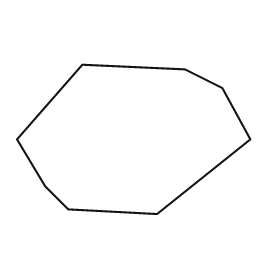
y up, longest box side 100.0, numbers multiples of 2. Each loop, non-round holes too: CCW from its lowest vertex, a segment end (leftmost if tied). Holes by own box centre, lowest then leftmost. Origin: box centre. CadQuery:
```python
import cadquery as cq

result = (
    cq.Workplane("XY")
    .moveTo(10.0, -32.0)
    .lineTo(50.0, 0.0)
    .lineTo(38.0, 22.0)
    .lineTo(22.0, 30.0)
    .lineTo(-22.0, 32.0)
    .lineTo(-50.0, 0.0)
    .lineTo(-38.0, -20.0)
    .lineTo(-28.0, -30.0)
    .close()
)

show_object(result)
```